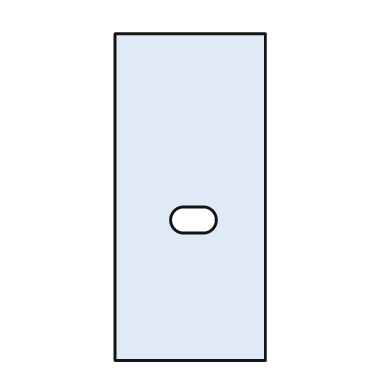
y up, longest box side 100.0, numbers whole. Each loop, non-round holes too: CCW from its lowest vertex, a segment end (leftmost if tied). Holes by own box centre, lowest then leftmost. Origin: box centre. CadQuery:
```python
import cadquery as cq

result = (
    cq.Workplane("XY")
    .moveTo(-23.0, -50.0)
    .lineTo(23.0, -50.0)
    .lineTo(23.0, 50.0)
    .lineTo(-23.0, 50.0)
    .close()
    .moveTo(-2.0, -11.0)
    .lineTo(4.0, -11.0)
    .threePointArc((8.0, -7.0), (4.0, -3.0))
    .lineTo(-2.0, -3.0)
    .threePointArc((-6.0, -7.0), (-2.0, -11.0))
    .close()
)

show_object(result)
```